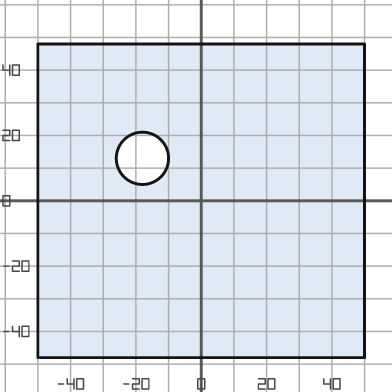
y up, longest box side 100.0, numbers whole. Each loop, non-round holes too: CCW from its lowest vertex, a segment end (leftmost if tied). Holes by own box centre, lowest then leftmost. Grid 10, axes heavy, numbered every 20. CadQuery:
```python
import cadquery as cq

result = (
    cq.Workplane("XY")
    .moveTo(-50.0, -48.0)
    .lineTo(50.0, -48.0)
    .lineTo(50.0, 48.0)
    .lineTo(-50.0, 48.0)
    .close()
    .moveTo(-18.0, 13.0)
    .circle(8.0)
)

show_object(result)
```